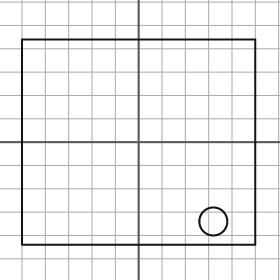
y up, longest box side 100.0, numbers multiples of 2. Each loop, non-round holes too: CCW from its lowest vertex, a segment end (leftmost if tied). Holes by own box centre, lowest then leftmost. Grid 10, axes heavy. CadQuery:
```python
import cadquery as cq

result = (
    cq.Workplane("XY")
    .moveTo(-50.0, -44.0)
    .lineTo(50.0, -44.0)
    .lineTo(50.0, 44.0)
    .lineTo(-50.0, 44.0)
    .close()
    .moveTo(32.0, -34.0)
    .circle(6.0)
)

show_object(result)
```